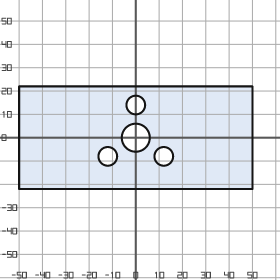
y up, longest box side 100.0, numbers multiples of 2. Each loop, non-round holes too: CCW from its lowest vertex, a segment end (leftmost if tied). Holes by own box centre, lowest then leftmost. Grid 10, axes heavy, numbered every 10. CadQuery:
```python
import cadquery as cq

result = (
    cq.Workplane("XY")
    .moveTo(-50.0, -22.0)
    .lineTo(50.0, -22.0)
    .lineTo(50.0, 22.0)
    .lineTo(-50.0, 22.0)
    .close()
    .moveTo(-12.0, -8.0)
    .circle(4.0)
    .moveTo(12.0, -8.0)
    .circle(4.0)
    .moveTo(0.0, 0.0)
    .circle(6.0)
    .moveTo(0.0, 14.0)
    .circle(4.0)
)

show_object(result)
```